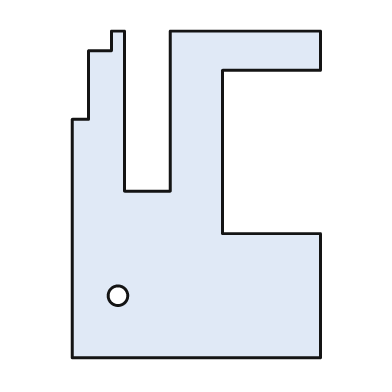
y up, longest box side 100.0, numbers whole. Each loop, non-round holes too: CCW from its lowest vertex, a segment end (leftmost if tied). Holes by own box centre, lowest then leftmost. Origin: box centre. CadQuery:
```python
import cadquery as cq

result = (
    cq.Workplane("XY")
    .moveTo(-38.0, -50.0)
    .lineTo(38.0, -50.0)
    .lineTo(38.0, -12.0)
    .lineTo(8.0, -12.0)
    .lineTo(8.0, 38.0)
    .lineTo(38.0, 38.0)
    .lineTo(38.0, 50.0)
    .lineTo(-8.0, 50.0)
    .lineTo(-8.0, 1.0)
    .lineTo(-22.0, 1.0)
    .lineTo(-22.0, 50.0)
    .lineTo(-26.0, 50.0)
    .lineTo(-26.0, 44.0)
    .lineTo(-33.0, 44.0)
    .lineTo(-33.0, 23.0)
    .lineTo(-38.0, 23.0)
    .close()
    .moveTo(-24.0, -31.0)
    .circle(3.0)
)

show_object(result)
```